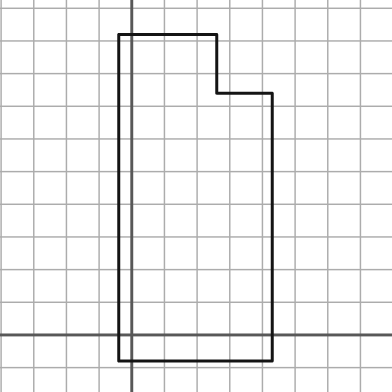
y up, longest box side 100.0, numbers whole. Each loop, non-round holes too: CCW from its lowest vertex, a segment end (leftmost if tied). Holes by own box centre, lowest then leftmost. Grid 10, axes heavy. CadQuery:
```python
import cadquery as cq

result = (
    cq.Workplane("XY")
    .moveTo(-4.0, -8.0)
    .lineTo(43.0, -8.0)
    .lineTo(43.0, 74.0)
    .lineTo(26.0, 74.0)
    .lineTo(26.0, 92.0)
    .lineTo(-4.0, 92.0)
    .close()
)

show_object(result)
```